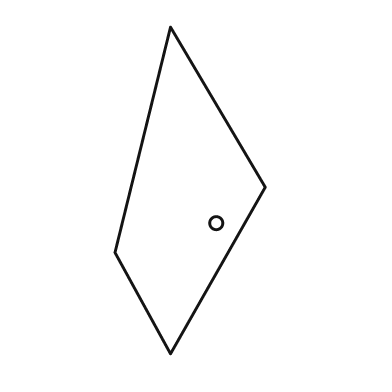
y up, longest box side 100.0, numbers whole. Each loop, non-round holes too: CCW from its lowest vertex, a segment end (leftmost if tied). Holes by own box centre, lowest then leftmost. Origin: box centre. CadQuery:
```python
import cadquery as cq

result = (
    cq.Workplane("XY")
    .moveTo(-6.0, -50.0)
    .lineTo(23.0, 1.0)
    .lineTo(-6.0, 50.0)
    .lineTo(-23.0, -19.0)
    .close()
    .moveTo(8.0, -10.0)
    .circle(2.0)
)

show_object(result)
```